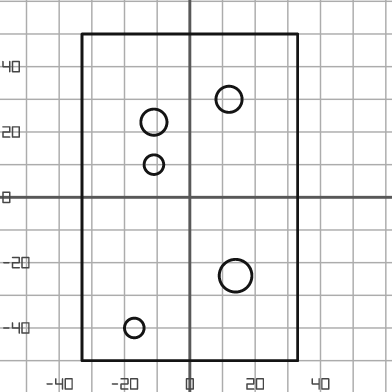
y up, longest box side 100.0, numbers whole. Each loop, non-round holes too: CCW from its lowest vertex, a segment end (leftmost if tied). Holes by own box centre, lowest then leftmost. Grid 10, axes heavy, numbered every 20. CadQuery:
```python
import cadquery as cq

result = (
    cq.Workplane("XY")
    .moveTo(-33.0, -50.0)
    .lineTo(33.0, -50.0)
    .lineTo(33.0, 50.0)
    .lineTo(-33.0, 50.0)
    .close()
    .moveTo(-17.0, -40.0)
    .circle(3.0)
    .moveTo(14.0, -24.0)
    .circle(5.0)
    .moveTo(-11.0, 10.0)
    .circle(3.0)
    .moveTo(-11.0, 23.0)
    .circle(4.0)
    .moveTo(12.0, 30.0)
    .circle(4.0)
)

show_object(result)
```